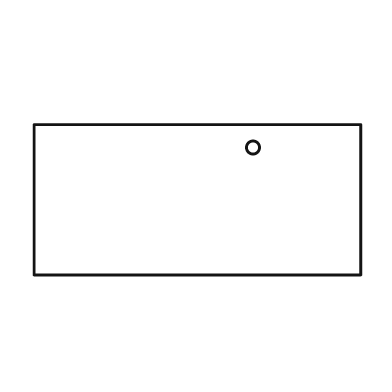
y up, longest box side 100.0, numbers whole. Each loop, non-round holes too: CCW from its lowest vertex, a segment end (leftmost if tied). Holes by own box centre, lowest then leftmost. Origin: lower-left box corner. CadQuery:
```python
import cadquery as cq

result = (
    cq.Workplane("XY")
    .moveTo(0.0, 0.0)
    .lineTo(100.0, 0.0)
    .lineTo(100.0, 46.0)
    .lineTo(0.0, 46.0)
    .close()
    .moveTo(67.0, 39.0)
    .circle(2.0)
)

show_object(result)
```